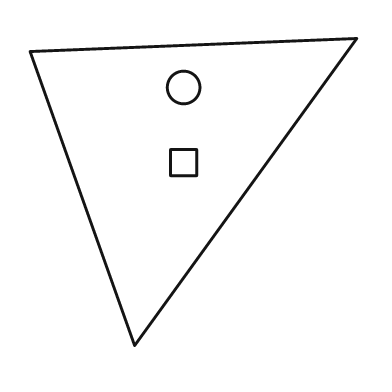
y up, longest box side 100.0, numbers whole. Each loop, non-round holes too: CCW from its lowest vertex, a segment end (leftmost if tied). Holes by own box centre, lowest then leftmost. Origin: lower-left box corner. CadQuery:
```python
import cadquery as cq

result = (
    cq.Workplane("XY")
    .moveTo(32.0, 0.0)
    .lineTo(100.0, 94.0)
    .lineTo(0.0, 90.0)
    .close()
    .moveTo(43.0, 52.0)
    .lineTo(51.0, 52.0)
    .lineTo(51.0, 60.0)
    .lineTo(43.0, 60.0)
    .close()
    .moveTo(47.0, 79.0)
    .circle(5.0)
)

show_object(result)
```